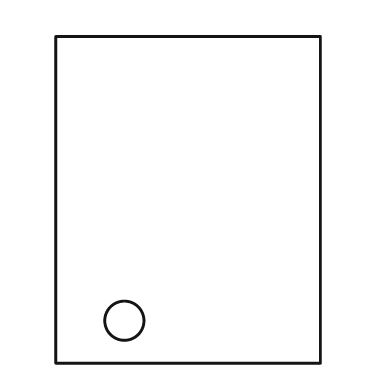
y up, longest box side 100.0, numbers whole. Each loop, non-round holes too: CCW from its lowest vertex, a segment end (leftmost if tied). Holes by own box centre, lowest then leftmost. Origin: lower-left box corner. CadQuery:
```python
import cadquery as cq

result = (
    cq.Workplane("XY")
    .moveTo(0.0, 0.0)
    .lineTo(81.0, 0.0)
    .lineTo(81.0, 100.0)
    .lineTo(0.0, 100.0)
    .close()
    .moveTo(21.0, 13.0)
    .circle(6.0)
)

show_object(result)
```